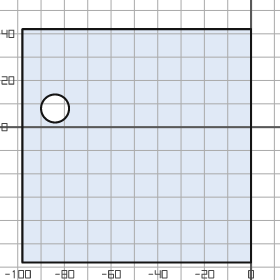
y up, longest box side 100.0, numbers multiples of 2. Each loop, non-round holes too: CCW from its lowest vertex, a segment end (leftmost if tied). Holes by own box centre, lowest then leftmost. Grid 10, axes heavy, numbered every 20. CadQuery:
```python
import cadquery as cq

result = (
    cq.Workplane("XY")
    .moveTo(-98.0, -58.0)
    .lineTo(0.0, -58.0)
    .lineTo(0.0, 42.0)
    .lineTo(-98.0, 42.0)
    .close()
    .moveTo(-84.0, 8.0)
    .circle(6.0)
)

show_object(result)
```